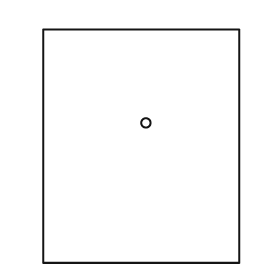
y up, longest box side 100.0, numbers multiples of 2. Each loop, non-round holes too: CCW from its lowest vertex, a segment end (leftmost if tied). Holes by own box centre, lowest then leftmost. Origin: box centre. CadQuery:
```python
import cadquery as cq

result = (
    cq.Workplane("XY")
    .moveTo(-42.0, -50.0)
    .lineTo(42.0, -50.0)
    .lineTo(42.0, 50.0)
    .lineTo(-42.0, 50.0)
    .close()
    .moveTo(2.0, 10.0)
    .circle(2.0)
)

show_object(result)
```